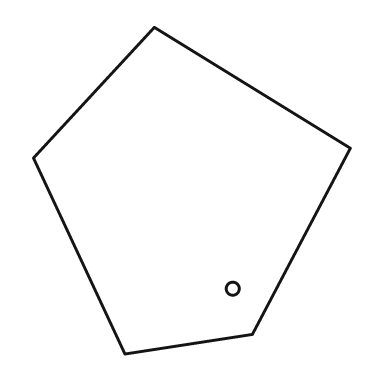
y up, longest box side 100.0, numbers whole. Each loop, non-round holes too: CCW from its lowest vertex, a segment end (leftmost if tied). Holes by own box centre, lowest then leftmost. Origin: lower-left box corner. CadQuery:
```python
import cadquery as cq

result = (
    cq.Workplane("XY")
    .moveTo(28.0, 0.0)
    .lineTo(67.0, 6.0)
    .lineTo(97.0, 63.0)
    .lineTo(37.0, 100.0)
    .lineTo(0.0, 60.0)
    .close()
    .moveTo(61.0, 20.0)
    .circle(2.0)
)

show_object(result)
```